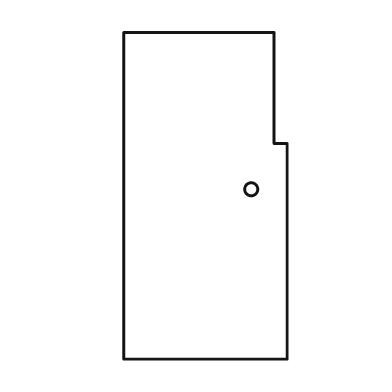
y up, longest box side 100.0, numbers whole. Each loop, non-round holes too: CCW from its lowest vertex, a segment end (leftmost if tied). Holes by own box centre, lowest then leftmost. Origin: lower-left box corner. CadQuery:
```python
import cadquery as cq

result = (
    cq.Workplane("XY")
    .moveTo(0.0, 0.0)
    .lineTo(50.0, 0.0)
    .lineTo(50.0, 66.0)
    .lineTo(46.0, 66.0)
    .lineTo(46.0, 100.0)
    .lineTo(0.0, 100.0)
    .close()
    .moveTo(39.0, 52.0)
    .circle(2.0)
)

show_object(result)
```